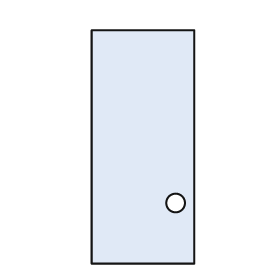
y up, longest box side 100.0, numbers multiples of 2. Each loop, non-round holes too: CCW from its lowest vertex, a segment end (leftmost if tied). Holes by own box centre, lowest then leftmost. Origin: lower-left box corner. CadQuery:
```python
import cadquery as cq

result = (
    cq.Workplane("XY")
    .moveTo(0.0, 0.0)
    .lineTo(44.0, 0.0)
    .lineTo(44.0, 100.0)
    .lineTo(0.0, 100.0)
    .close()
    .moveTo(36.0, 26.0)
    .circle(4.0)
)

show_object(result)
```